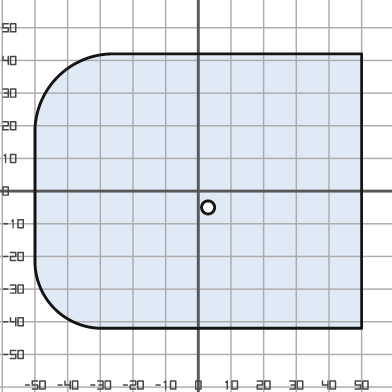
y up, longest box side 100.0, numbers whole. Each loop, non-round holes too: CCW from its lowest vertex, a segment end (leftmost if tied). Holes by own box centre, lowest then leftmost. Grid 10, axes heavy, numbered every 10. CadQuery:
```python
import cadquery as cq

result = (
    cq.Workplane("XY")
    .moveTo(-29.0, -42.0)
    .lineTo(50.0, -42.0)
    .lineTo(50.0, 42.0)
    .lineTo(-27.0, 42.0)
    .threePointArc((-43.0, 35.0), (-50.0, 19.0))
    .lineTo(-50.0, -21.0)
    .threePointArc((-44.0, -36.0), (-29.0, -42.0))
    .close()
    .moveTo(3.0, -5.0)
    .circle(2.0)
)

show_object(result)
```